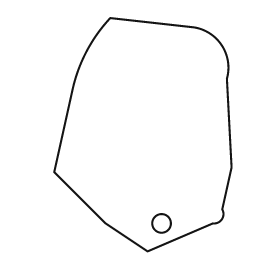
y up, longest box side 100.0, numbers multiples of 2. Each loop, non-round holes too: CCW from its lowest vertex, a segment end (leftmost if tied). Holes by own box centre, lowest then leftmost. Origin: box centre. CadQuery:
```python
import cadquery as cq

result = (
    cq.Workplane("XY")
    .moveTo(2.0, -50.0)
    .lineTo(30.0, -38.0)
    .threePointArc((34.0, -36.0), (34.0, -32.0))
    .lineTo(38.0, -14.0)
    .lineTo(36.0, 24.0)
    .threePointArc((34.0, 38.0), (22.0, 46.0))
    .lineTo(-14.0, 50.0)
    .threePointArc((-24.0, 36.0), (-30.0, 20.0))
    .lineTo(-38.0, -16.0)
    .lineTo(-16.0, -38.0)
    .close()
    .moveTo(8.0, -38.0)
    .circle(4.0)
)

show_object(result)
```